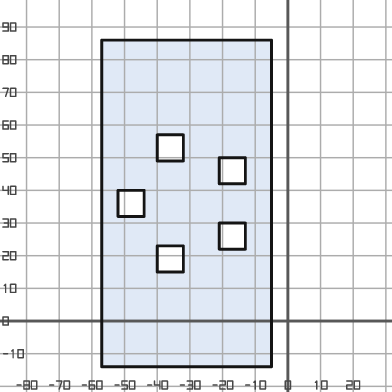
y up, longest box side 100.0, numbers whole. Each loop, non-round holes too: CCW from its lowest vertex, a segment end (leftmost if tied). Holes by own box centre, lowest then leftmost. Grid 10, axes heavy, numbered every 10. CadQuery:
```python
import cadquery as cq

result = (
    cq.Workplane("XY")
    .moveTo(-57.0, -14.0)
    .lineTo(-5.0, -14.0)
    .lineTo(-5.0, 86.0)
    .lineTo(-57.0, 86.0)
    .close()
    .moveTo(-40.0, 15.0)
    .lineTo(-32.0, 15.0)
    .lineTo(-32.0, 23.0)
    .lineTo(-40.0, 23.0)
    .close()
    .moveTo(-21.0, 22.0)
    .lineTo(-13.0, 22.0)
    .lineTo(-13.0, 30.0)
    .lineTo(-21.0, 30.0)
    .close()
    .moveTo(-52.0, 32.0)
    .lineTo(-44.0, 32.0)
    .lineTo(-44.0, 40.0)
    .lineTo(-52.0, 40.0)
    .close()
    .moveTo(-21.0, 42.0)
    .lineTo(-13.0, 42.0)
    .lineTo(-13.0, 50.0)
    .lineTo(-21.0, 50.0)
    .close()
    .moveTo(-40.0, 49.0)
    .lineTo(-32.0, 49.0)
    .lineTo(-32.0, 57.0)
    .lineTo(-40.0, 57.0)
    .close()
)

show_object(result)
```